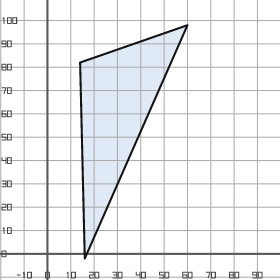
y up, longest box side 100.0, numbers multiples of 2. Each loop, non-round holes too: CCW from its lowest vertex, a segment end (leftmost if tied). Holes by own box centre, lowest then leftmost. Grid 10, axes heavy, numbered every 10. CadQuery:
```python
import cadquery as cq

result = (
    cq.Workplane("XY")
    .moveTo(16.0, -2.0)
    .lineTo(60.0, 98.0)
    .lineTo(14.0, 82.0)
    .close()
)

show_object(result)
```